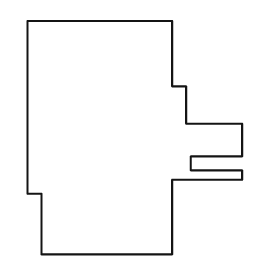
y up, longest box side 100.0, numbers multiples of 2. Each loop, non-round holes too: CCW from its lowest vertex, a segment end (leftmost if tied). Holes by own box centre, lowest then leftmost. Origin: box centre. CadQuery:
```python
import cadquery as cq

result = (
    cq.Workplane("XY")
    .moveTo(-40.0, -50.0)
    .lineTo(16.0, -50.0)
    .lineTo(16.0, -18.0)
    .lineTo(46.0, -18.0)
    .lineTo(46.0, -14.0)
    .lineTo(24.0, -14.0)
    .lineTo(24.0, -8.0)
    .lineTo(46.0, -8.0)
    .lineTo(46.0, 6.0)
    .lineTo(22.0, 6.0)
    .lineTo(22.0, 22.0)
    .lineTo(16.0, 22.0)
    .lineTo(16.0, 50.0)
    .lineTo(-46.0, 50.0)
    .lineTo(-46.0, -24.0)
    .lineTo(-40.0, -24.0)
    .close()
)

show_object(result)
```